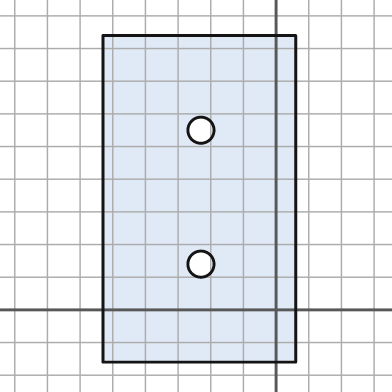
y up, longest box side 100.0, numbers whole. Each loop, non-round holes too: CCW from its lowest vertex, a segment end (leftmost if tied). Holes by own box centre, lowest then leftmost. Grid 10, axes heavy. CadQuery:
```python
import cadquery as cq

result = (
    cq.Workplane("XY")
    .moveTo(-53.0, -16.0)
    .lineTo(6.0, -16.0)
    .lineTo(6.0, 84.0)
    .lineTo(-53.0, 84.0)
    .close()
    .moveTo(-23.0, 14.0)
    .circle(4.0)
    .moveTo(-23.0, 55.0)
    .circle(4.0)
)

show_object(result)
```